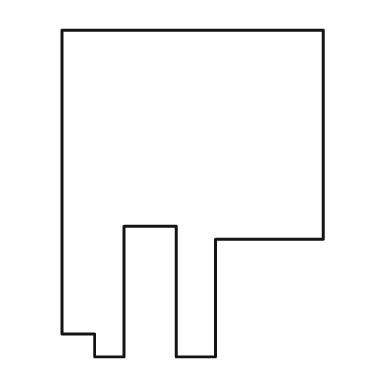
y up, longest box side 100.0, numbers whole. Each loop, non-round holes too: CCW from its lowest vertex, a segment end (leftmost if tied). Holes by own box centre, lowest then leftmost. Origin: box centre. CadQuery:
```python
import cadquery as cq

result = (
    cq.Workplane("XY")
    .moveTo(-30.0, -50.0)
    .lineTo(-21.0, -50.0)
    .lineTo(-21.0, -10.0)
    .lineTo(-5.0, -10.0)
    .lineTo(-5.0, -50.0)
    .lineTo(7.0, -50.0)
    .lineTo(7.0, -14.0)
    .lineTo(40.0, -14.0)
    .lineTo(40.0, 50.0)
    .lineTo(-40.0, 50.0)
    .lineTo(-40.0, -43.0)
    .lineTo(-30.0, -43.0)
    .close()
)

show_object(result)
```